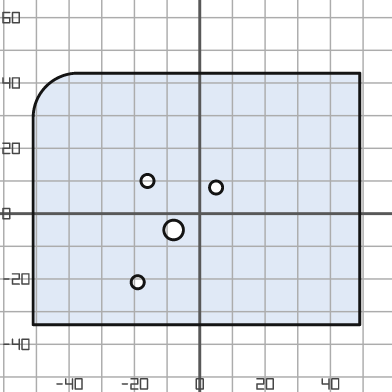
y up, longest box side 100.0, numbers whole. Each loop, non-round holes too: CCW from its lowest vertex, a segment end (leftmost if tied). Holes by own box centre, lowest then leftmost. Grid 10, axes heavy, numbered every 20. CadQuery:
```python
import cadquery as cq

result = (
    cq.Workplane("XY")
    .moveTo(-51.0, -34.0)
    .lineTo(49.0, -34.0)
    .lineTo(49.0, 43.0)
    .lineTo(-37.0, 43.0)
    .threePointArc((-47.0, 39.0), (-51.0, 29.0))
    .close()
    .moveTo(-19.0, -21.0)
    .circle(2.0)
    .moveTo(-8.0, -5.0)
    .circle(3.0)
    .moveTo(5.0, 8.0)
    .circle(2.0)
    .moveTo(-16.0, 10.0)
    .circle(2.0)
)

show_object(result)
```